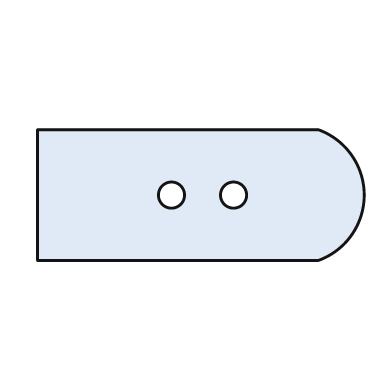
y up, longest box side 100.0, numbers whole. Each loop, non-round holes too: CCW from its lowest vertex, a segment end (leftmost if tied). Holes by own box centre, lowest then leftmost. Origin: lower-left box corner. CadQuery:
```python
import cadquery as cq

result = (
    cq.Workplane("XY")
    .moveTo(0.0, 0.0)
    .lineTo(86.0, 0.0)
    .threePointArc((100.0, 20.0), (86.0, 40.0))
    .lineTo(0.0, 40.0)
    .close()
    .moveTo(41.0, 20.0)
    .circle(4.0)
    .moveTo(60.0, 20.0)
    .circle(4.0)
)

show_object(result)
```